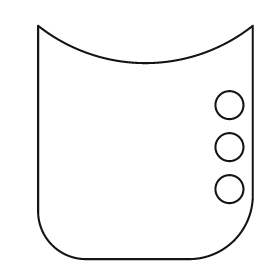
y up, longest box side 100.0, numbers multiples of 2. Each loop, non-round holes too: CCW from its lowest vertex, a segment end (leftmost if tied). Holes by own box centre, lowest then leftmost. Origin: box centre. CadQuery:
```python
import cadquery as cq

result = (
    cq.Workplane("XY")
    .moveTo(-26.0, -50.0)
    .lineTo(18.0, -50.0)
    .threePointArc((38.0, -42.0), (46.0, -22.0))
    .lineTo(46.0, 50.0)
    .threePointArc((0.0, 34.0), (-46.0, 50.0))
    .lineTo(-46.0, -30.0)
    .threePointArc((-40.0, -44.0), (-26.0, -50.0))
    .close()
    .moveTo(36.0, -20.0)
    .circle(6.0)
    .moveTo(36.0, -2.0)
    .circle(6.0)
    .moveTo(36.0, 16.0)
    .circle(6.0)
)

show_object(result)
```